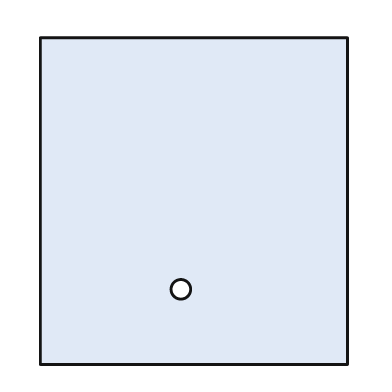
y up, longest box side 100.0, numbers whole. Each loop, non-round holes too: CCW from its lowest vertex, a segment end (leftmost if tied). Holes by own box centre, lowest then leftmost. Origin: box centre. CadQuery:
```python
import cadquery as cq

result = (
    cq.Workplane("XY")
    .moveTo(-47.0, -50.0)
    .lineTo(47.0, -50.0)
    .lineTo(47.0, 50.0)
    .lineTo(-47.0, 50.0)
    .close()
    .moveTo(-4.0, -27.0)
    .circle(3.0)
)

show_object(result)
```